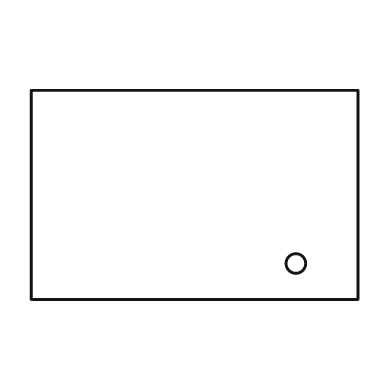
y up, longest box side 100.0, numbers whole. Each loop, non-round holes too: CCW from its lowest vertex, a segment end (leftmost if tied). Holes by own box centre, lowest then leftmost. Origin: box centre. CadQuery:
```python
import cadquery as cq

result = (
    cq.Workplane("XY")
    .moveTo(-50.0, -32.0)
    .lineTo(50.0, -32.0)
    .lineTo(50.0, 32.0)
    .lineTo(-50.0, 32.0)
    .close()
    .moveTo(31.0, -21.0)
    .circle(3.0)
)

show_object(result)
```